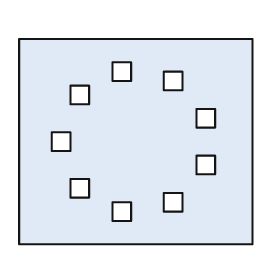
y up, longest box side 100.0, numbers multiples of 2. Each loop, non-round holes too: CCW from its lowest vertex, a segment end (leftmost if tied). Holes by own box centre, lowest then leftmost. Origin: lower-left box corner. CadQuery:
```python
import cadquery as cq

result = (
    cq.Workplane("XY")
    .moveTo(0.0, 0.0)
    .lineTo(100.0, 0.0)
    .lineTo(100.0, 88.0)
    .lineTo(0.0, 88.0)
    .close()
    .moveTo(40.0, 10.0)
    .lineTo(48.0, 10.0)
    .lineTo(48.0, 18.0)
    .lineTo(40.0, 18.0)
    .close()
    .moveTo(62.0, 14.0)
    .lineTo(70.0, 14.0)
    .lineTo(70.0, 22.0)
    .lineTo(62.0, 22.0)
    .close()
    .moveTo(22.0, 20.0)
    .lineTo(30.0, 20.0)
    .lineTo(30.0, 28.0)
    .lineTo(22.0, 28.0)
    .close()
    .moveTo(76.0, 30.0)
    .lineTo(84.0, 30.0)
    .lineTo(84.0, 38.0)
    .lineTo(76.0, 38.0)
    .close()
    .moveTo(14.0, 40.0)
    .lineTo(22.0, 40.0)
    .lineTo(22.0, 48.0)
    .lineTo(14.0, 48.0)
    .close()
    .moveTo(76.0, 50.0)
    .lineTo(84.0, 50.0)
    .lineTo(84.0, 58.0)
    .lineTo(76.0, 58.0)
    .close()
    .moveTo(22.0, 60.0)
    .lineTo(30.0, 60.0)
    .lineTo(30.0, 68.0)
    .lineTo(22.0, 68.0)
    .close()
    .moveTo(62.0, 66.0)
    .lineTo(70.0, 66.0)
    .lineTo(70.0, 74.0)
    .lineTo(62.0, 74.0)
    .close()
    .moveTo(40.0, 70.0)
    .lineTo(48.0, 70.0)
    .lineTo(48.0, 78.0)
    .lineTo(40.0, 78.0)
    .close()
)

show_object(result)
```